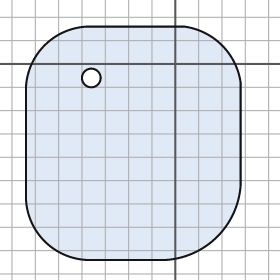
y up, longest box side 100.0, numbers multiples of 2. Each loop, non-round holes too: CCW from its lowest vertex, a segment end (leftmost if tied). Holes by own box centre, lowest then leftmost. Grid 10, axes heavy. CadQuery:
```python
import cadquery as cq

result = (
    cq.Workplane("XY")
    .moveTo(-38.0, -84.0)
    .lineTo(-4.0, -84.0)
    .threePointArc((18.0, -74.0), (28.0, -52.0))
    .lineTo(28.0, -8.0)
    .threePointArc((20.0, 8.0), (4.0, 16.0))
    .lineTo(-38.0, 16.0)
    .threePointArc((-56.0, 8.0), (-64.0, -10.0))
    .lineTo(-64.0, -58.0)
    .threePointArc((-56.0, -76.0), (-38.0, -84.0))
    .close()
    .moveTo(-36.0, -6.0)
    .circle(4.0)
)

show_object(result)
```